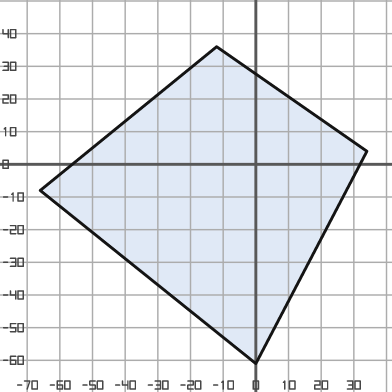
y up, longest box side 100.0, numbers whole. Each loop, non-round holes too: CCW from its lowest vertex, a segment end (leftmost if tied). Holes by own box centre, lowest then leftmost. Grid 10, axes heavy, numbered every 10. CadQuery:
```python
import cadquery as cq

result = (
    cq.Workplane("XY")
    .moveTo(0.0, -61.0)
    .lineTo(34.0, 4.0)
    .lineTo(-12.0, 36.0)
    .lineTo(-66.0, -8.0)
    .close()
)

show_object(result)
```